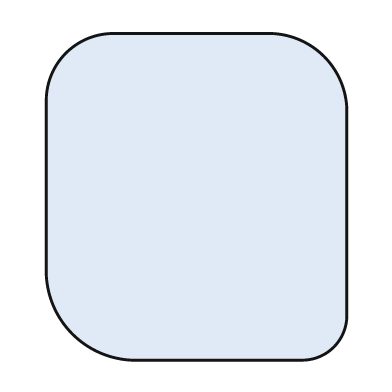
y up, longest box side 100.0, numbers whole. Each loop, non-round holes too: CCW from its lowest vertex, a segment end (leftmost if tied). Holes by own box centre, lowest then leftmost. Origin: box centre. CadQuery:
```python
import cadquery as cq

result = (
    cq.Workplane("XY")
    .moveTo(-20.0, -50.0)
    .lineTo(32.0, -50.0)
    .threePointArc((42.0, -46.0), (46.0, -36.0))
    .lineTo(46.0, 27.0)
    .threePointArc((39.0, 43.0), (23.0, 50.0))
    .lineTo(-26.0, 50.0)
    .threePointArc((-40.0, 44.0), (-46.0, 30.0))
    .lineTo(-46.0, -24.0)
    .threePointArc((-38.0, -42.0), (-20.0, -50.0))
    .close()
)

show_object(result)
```